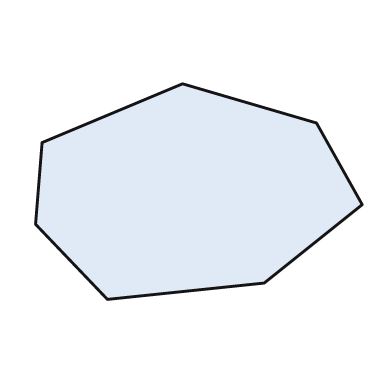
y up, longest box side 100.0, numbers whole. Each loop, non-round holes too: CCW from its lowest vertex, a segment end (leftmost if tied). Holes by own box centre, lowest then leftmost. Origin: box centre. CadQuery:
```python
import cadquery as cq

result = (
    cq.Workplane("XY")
    .moveTo(-28.0, -33.0)
    .lineTo(20.0, -28.0)
    .lineTo(50.0, -4.0)
    .lineTo(36.0, 21.0)
    .lineTo(-5.0, 33.0)
    .lineTo(-48.0, 15.0)
    .lineTo(-50.0, -10.0)
    .close()
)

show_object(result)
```